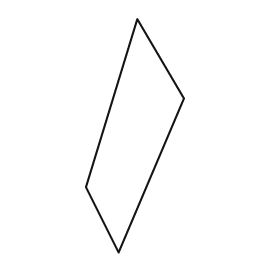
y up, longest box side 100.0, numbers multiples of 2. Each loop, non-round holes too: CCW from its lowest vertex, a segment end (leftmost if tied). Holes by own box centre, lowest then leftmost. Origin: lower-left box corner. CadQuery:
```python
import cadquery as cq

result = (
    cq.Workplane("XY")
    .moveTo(14.0, 0.0)
    .lineTo(42.0, 66.0)
    .lineTo(22.0, 100.0)
    .lineTo(0.0, 28.0)
    .close()
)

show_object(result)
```